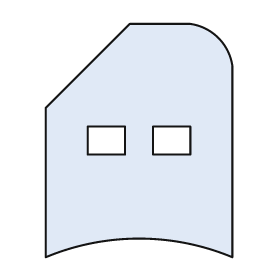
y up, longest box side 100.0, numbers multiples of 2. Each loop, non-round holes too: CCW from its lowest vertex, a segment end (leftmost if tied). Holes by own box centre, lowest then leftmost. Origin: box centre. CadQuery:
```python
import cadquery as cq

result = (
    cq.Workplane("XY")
    .moveTo(-40.0, -50.0)
    .threePointArc((0.0, -42.0), (40.0, -50.0))
    .lineTo(40.0, 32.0)
    .threePointArc((34.0, 44.0), (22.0, 50.0))
    .lineTo(-4.0, 50.0)
    .lineTo(-40.0, 14.0)
    .close()
    .moveTo(-22.0, -6.0)
    .lineTo(-6.0, -6.0)
    .lineTo(-6.0, 6.0)
    .lineTo(-22.0, 6.0)
    .close()
    .moveTo(6.0, -6.0)
    .lineTo(22.0, -6.0)
    .lineTo(22.0, 6.0)
    .lineTo(6.0, 6.0)
    .close()
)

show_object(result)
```